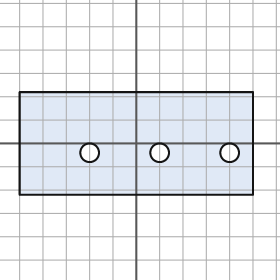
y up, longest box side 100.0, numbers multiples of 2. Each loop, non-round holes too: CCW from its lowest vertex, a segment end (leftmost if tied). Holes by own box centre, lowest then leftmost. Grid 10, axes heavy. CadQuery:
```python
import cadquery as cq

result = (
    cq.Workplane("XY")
    .moveTo(-50.0, -22.0)
    .lineTo(50.0, -22.0)
    .lineTo(50.0, 22.0)
    .lineTo(-50.0, 22.0)
    .close()
    .moveTo(-20.0, -4.0)
    .circle(4.0)
    .moveTo(10.0, -4.0)
    .circle(4.0)
    .moveTo(40.0, -4.0)
    .circle(4.0)
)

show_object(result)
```